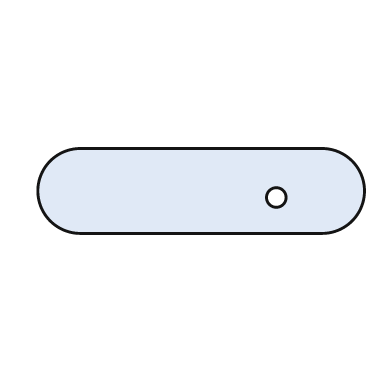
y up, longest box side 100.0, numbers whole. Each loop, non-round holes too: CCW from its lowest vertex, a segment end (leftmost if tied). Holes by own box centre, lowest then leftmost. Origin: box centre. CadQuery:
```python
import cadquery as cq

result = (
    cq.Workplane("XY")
    .moveTo(-37.0, -13.0)
    .lineTo(37.0, -13.0)
    .threePointArc((50.0, 0.0), (37.0, 13.0))
    .lineTo(-37.0, 13.0)
    .threePointArc((-50.0, 0.0), (-37.0, -13.0))
    .close()
    .moveTo(23.0, -2.0)
    .circle(3.0)
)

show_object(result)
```